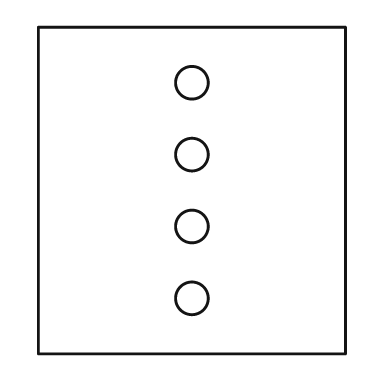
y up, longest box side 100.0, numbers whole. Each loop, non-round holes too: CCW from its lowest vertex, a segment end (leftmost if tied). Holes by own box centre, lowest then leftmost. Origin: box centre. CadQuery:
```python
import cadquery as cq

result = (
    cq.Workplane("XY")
    .moveTo(-47.0, -50.0)
    .lineTo(47.0, -50.0)
    .lineTo(47.0, 50.0)
    .lineTo(-47.0, 50.0)
    .close()
    .moveTo(0.0, -33.0)
    .circle(5.0)
    .moveTo(0.0, -11.0)
    .circle(5.0)
    .moveTo(0.0, 11.0)
    .circle(5.0)
    .moveTo(0.0, 33.0)
    .circle(5.0)
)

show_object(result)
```